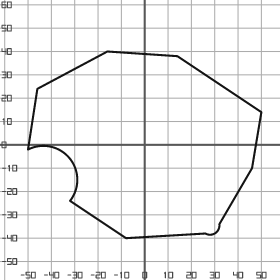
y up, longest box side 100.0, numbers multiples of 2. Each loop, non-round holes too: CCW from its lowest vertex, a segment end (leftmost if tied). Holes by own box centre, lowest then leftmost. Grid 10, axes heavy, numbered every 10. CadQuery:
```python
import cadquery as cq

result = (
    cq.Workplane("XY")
    .moveTo(-8.0, -40.0)
    .lineTo(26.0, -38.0)
    .threePointArc((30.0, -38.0), (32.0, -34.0))
    .lineTo(46.0, -10.0)
    .lineTo(50.0, 14.0)
    .lineTo(14.0, 38.0)
    .lineTo(-16.0, 40.0)
    .lineTo(-46.0, 24.0)
    .lineTo(-50.0, -2.0)
    .threePointArc((-32.0, -6.0), (-32.0, -24.0))
    .close()
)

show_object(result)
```